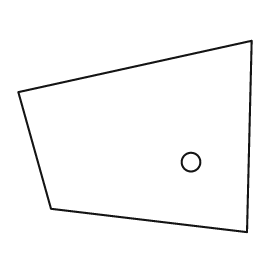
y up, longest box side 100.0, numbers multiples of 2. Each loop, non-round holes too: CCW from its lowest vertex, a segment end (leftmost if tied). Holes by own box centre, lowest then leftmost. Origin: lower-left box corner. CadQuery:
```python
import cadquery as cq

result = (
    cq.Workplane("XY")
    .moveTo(98.0, 0.0)
    .lineTo(100.0, 82.0)
    .lineTo(0.0, 60.0)
    .lineTo(14.0, 10.0)
    .close()
    .moveTo(74.0, 30.0)
    .circle(4.0)
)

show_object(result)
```